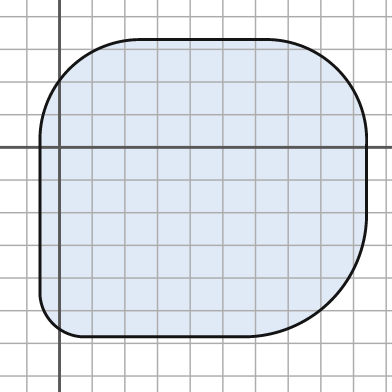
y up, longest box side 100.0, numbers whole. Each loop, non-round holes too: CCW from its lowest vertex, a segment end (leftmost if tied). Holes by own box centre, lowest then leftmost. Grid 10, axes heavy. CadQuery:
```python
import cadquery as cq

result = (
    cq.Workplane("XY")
    .moveTo(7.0, -58.0)
    .lineTo(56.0, -58.0)
    .threePointArc((83.0, -47.0), (94.0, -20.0))
    .lineTo(94.0, 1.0)
    .threePointArc((85.0, 24.0), (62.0, 33.0))
    .lineTo(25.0, 33.0)
    .threePointArc((3.0, 24.0), (-6.0, 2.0))
    .lineTo(-6.0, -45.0)
    .threePointArc((-2.0, -54.0), (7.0, -58.0))
    .close()
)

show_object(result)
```